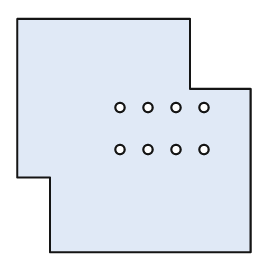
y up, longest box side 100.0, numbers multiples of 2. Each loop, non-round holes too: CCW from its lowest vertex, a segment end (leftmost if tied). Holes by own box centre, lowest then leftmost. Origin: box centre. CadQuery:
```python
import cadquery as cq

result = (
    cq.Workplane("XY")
    .moveTo(-36.0, -50.0)
    .lineTo(50.0, -50.0)
    .lineTo(50.0, 20.0)
    .lineTo(24.0, 20.0)
    .lineTo(24.0, 50.0)
    .lineTo(-50.0, 50.0)
    .lineTo(-50.0, -18.0)
    .lineTo(-36.0, -18.0)
    .close()
    .moveTo(-6.0, -6.0)
    .circle(2.0)
    .moveTo(6.0, -6.0)
    .circle(2.0)
    .moveTo(18.0, -6.0)
    .circle(2.0)
    .moveTo(30.0, -6.0)
    .circle(2.0)
    .moveTo(-6.0, 12.0)
    .circle(2.0)
    .moveTo(6.0, 12.0)
    .circle(2.0)
    .moveTo(18.0, 12.0)
    .circle(2.0)
    .moveTo(30.0, 12.0)
    .circle(2.0)
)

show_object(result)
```